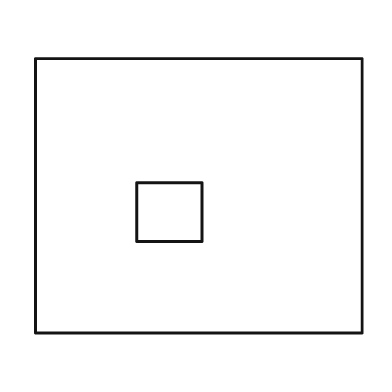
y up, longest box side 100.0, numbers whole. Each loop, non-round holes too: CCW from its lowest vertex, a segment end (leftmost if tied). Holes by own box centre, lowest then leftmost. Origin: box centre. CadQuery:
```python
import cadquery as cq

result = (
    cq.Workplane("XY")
    .moveTo(-50.0, -42.0)
    .lineTo(50.0, -42.0)
    .lineTo(50.0, 42.0)
    .lineTo(-50.0, 42.0)
    .close()
    .moveTo(-19.0, -14.0)
    .lineTo(1.0, -14.0)
    .lineTo(1.0, 4.0)
    .lineTo(-19.0, 4.0)
    .close()
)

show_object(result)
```